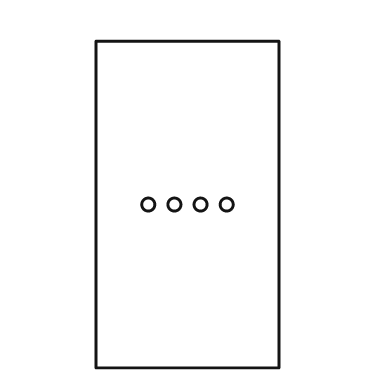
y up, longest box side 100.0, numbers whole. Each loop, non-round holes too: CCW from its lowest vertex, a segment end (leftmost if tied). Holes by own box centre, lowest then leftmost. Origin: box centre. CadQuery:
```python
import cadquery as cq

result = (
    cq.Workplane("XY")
    .moveTo(-28.0, -50.0)
    .lineTo(28.0, -50.0)
    .lineTo(28.0, 50.0)
    .lineTo(-28.0, 50.0)
    .close()
    .moveTo(-12.0, 0.0)
    .circle(2.0)
    .moveTo(-4.0, 0.0)
    .circle(2.0)
    .moveTo(4.0, 0.0)
    .circle(2.0)
    .moveTo(12.0, 0.0)
    .circle(2.0)
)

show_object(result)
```